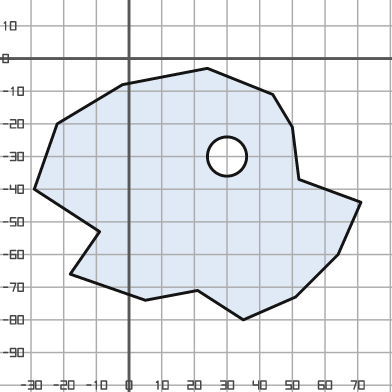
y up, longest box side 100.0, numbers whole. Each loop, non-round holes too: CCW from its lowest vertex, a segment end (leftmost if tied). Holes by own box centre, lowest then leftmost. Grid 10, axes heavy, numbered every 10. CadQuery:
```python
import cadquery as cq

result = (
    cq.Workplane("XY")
    .moveTo(35.0, -80.0)
    .lineTo(51.0, -73.0)
    .lineTo(64.0, -60.0)
    .lineTo(71.0, -44.0)
    .lineTo(52.0, -37.0)
    .lineTo(50.0, -21.0)
    .lineTo(44.0, -11.0)
    .lineTo(24.0, -3.0)
    .lineTo(-2.0, -8.0)
    .lineTo(-22.0, -20.0)
    .lineTo(-29.0, -40.0)
    .lineTo(-9.0, -53.0)
    .lineTo(-18.0, -66.0)
    .lineTo(5.0, -74.0)
    .lineTo(21.0, -71.0)
    .close()
    .moveTo(30.0, -30.0)
    .circle(6.0)
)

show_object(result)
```